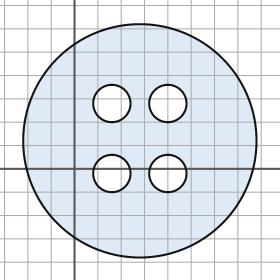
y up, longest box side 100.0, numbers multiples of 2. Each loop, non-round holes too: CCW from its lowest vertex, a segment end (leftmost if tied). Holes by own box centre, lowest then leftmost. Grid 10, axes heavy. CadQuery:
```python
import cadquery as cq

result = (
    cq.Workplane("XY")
    .moveTo(28.0, 12.0)
    .circle(50.0)
    .moveTo(16.0, -2.0)
    .circle(8.0)
    .moveTo(40.0, -2.0)
    .circle(8.0)
    .moveTo(16.0, 28.0)
    .circle(8.0)
    .moveTo(40.0, 28.0)
    .circle(8.0)
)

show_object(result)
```